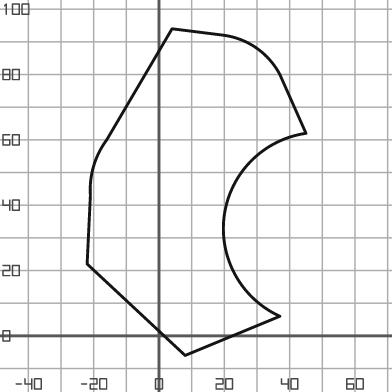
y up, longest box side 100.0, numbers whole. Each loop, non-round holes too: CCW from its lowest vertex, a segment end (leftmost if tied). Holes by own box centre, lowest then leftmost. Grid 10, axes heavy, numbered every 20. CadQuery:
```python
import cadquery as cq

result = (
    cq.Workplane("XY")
    .moveTo(8.0, -6.0)
    .lineTo(37.0, 6.0)
    .threePointArc((20.0, 37.0), (45.0, 62.0))
    .lineTo(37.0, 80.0)
    .threePointArc((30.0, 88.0), (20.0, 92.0))
    .lineTo(4.0, 94.0)
    .lineTo(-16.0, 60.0)
    .threePointArc((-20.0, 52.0), (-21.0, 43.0))
    .lineTo(-22.0, 22.0)
    .close()
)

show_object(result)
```